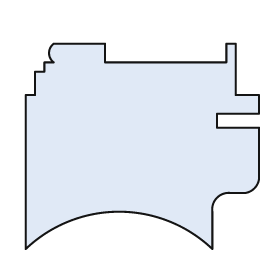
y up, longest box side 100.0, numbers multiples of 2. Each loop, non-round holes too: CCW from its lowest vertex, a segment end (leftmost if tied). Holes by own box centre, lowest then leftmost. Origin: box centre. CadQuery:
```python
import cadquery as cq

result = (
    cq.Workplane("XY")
    .moveTo(-50.0, -44.0)
    .threePointArc((-10.0, -28.0), (30.0, -44.0))
    .lineTo(30.0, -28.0)
    .threePointArc((32.0, -22.0), (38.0, -20.0))
    .lineTo(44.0, -20.0)
    .threePointArc((48.0, -18.0), (50.0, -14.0))
    .lineTo(50.0, 8.0)
    .lineTo(32.0, 8.0)
    .lineTo(32.0, 14.0)
    .lineTo(50.0, 14.0)
    .lineTo(50.0, 22.0)
    .lineTo(40.0, 22.0)
    .lineTo(40.0, 44.0)
    .lineTo(36.0, 44.0)
    .lineTo(36.0, 36.0)
    .lineTo(-16.0, 36.0)
    .lineTo(-16.0, 44.0)
    .lineTo(-38.0, 44.0)
    .threePointArc((-40.0, 40.0), (-38.0, 36.0))
    .lineTo(-42.0, 36.0)
    .lineTo(-42.0, 32.0)
    .lineTo(-46.0, 32.0)
    .lineTo(-46.0, 22.0)
    .lineTo(-50.0, 22.0)
    .close()
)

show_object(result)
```